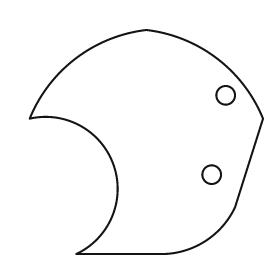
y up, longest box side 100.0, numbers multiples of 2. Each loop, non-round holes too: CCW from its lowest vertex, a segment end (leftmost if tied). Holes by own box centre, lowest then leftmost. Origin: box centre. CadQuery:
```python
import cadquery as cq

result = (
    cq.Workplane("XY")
    .moveTo(-30.0, -48.0)
    .lineTo(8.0, -48.0)
    .threePointArc((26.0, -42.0), (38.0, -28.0))
    .lineTo(50.0, 10.0)
    .threePointArc((30.0, 36.0), (0.0, 48.0))
    .threePointArc((-30.0, 36.0), (-50.0, 10.0))
    .threePointArc((-14.0, -10.0), (-30.0, -48.0))
    .close()
    .moveTo(28.0, -14.0)
    .circle(4.0)
    .moveTo(34.0, 20.0)
    .circle(4.0)
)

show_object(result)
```